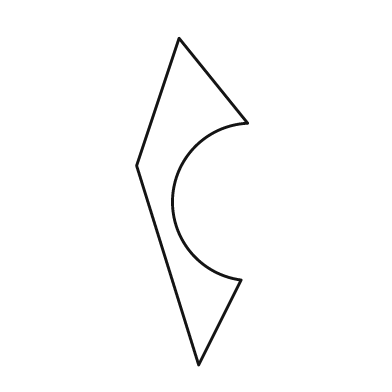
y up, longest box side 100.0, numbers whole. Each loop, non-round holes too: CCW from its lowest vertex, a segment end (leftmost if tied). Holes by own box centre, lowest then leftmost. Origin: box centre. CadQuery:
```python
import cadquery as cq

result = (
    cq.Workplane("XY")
    .moveTo(2.0, -50.0)
    .lineTo(15.0, -24.0)
    .threePointArc((-6.0, 1.0), (17.0, 24.0))
    .lineTo(-4.0, 50.0)
    .lineTo(-17.0, 11.0)
    .close()
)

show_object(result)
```